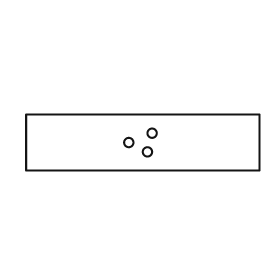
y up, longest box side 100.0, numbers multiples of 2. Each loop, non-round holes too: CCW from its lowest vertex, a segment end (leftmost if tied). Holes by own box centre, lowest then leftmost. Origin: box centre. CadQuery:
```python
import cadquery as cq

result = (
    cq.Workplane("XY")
    .moveTo(-50.0, -12.0)
    .lineTo(50.0, -12.0)
    .lineTo(50.0, 12.0)
    .lineTo(-50.0, 12.0)
    .close()
    .moveTo(2.0, -4.0)
    .circle(2.0)
    .moveTo(-6.0, 0.0)
    .circle(2.0)
    .moveTo(4.0, 4.0)
    .circle(2.0)
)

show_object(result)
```